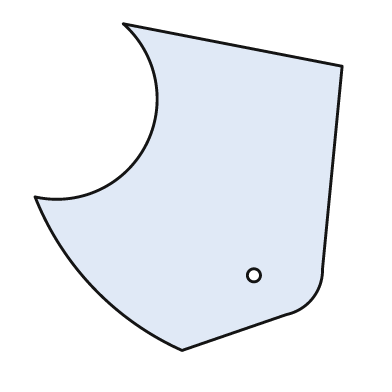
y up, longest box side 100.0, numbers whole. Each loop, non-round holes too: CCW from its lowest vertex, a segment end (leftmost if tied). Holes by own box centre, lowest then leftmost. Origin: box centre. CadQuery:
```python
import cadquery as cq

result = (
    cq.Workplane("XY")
    .moveTo(-2.0, -50.0)
    .lineTo(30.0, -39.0)
    .threePointArc((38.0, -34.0), (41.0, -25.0))
    .lineTo(47.0, 37.0)
    .lineTo(-20.0, 50.0)
    .threePointArc((-13.0, 13.0), (-47.0, -3.0))
    .threePointArc((-29.0, -31.0), (-2.0, -50.0))
    .close()
    .moveTo(20.0, -27.0)
    .circle(2.0)
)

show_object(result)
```